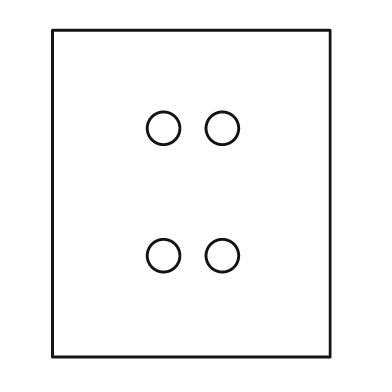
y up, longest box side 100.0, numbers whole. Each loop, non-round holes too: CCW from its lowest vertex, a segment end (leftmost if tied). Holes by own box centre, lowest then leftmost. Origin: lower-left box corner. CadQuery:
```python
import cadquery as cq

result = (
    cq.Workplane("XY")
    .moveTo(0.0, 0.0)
    .lineTo(85.0, 0.0)
    .lineTo(85.0, 100.0)
    .lineTo(0.0, 100.0)
    .close()
    .moveTo(34.0, 31.0)
    .circle(5.0)
    .moveTo(52.0, 31.0)
    .circle(5.0)
    .moveTo(34.0, 70.0)
    .circle(5.0)
    .moveTo(52.0, 70.0)
    .circle(5.0)
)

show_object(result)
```